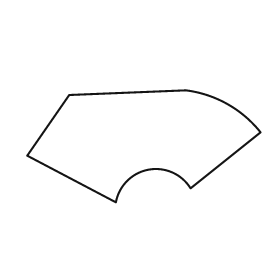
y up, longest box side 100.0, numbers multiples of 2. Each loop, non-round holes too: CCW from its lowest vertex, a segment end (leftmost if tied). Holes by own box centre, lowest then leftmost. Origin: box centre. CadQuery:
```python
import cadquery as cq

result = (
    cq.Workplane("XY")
    .moveTo(-12.0, -24.0)
    .threePointArc((2.0, -10.0), (20.0, -18.0))
    .lineTo(50.0, 6.0)
    .threePointArc((36.0, 18.0), (18.0, 24.0))
    .lineTo(-32.0, 22.0)
    .lineTo(-50.0, -4.0)
    .close()
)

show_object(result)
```